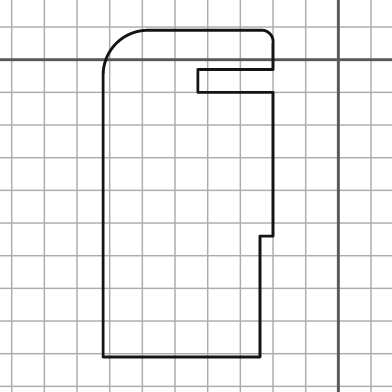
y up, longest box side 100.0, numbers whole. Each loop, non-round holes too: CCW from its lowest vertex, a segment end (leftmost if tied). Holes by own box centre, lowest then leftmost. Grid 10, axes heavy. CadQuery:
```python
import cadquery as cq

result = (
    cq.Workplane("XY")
    .moveTo(-72.0, -91.0)
    .lineTo(-24.0, -91.0)
    .lineTo(-24.0, -54.0)
    .lineTo(-20.0, -54.0)
    .lineTo(-20.0, -10.0)
    .lineTo(-43.0, -10.0)
    .lineTo(-43.0, -3.0)
    .lineTo(-20.0, -3.0)
    .lineTo(-20.0, 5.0)
    .threePointArc((-21.0, 8.0), (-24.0, 9.0))
    .lineTo(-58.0, 9.0)
    .threePointArc((-68.0, 5.0), (-72.0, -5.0))
    .close()
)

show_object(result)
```